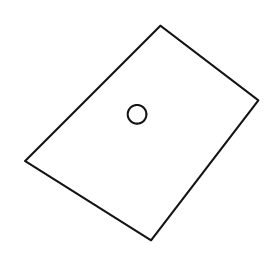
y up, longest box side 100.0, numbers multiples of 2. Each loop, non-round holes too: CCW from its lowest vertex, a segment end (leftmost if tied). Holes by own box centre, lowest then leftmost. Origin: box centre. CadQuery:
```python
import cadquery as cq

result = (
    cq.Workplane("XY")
    .moveTo(4.0, -46.0)
    .lineTo(50.0, 14.0)
    .lineTo(8.0, 46.0)
    .lineTo(-50.0, -12.0)
    .close()
    .moveTo(-2.0, 8.0)
    .circle(4.0)
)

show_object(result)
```